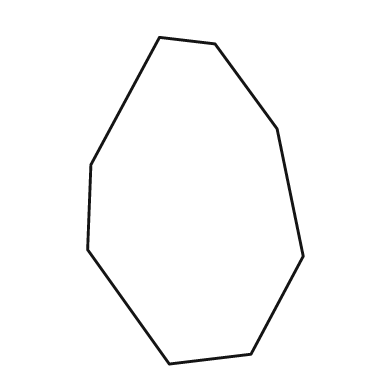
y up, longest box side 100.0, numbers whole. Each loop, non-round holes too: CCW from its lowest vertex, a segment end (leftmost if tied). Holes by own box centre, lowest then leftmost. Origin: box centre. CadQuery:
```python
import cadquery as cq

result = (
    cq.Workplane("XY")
    .moveTo(-8.0, -50.0)
    .lineTo(17.0, -47.0)
    .lineTo(33.0, -17.0)
    .lineTo(25.0, 22.0)
    .lineTo(6.0, 48.0)
    .lineTo(-11.0, 50.0)
    .lineTo(-32.0, 11.0)
    .lineTo(-33.0, -15.0)
    .close()
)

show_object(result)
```